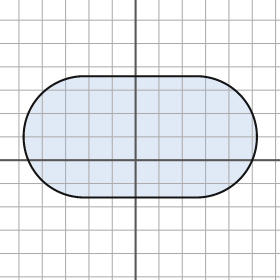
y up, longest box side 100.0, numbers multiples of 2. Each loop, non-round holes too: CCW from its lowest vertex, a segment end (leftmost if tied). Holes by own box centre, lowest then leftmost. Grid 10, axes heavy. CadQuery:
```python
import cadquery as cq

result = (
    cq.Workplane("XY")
    .moveTo(-22.0, -16.0)
    .lineTo(26.0, -16.0)
    .threePointArc((52.0, 10.0), (26.0, 36.0))
    .lineTo(-22.0, 36.0)
    .threePointArc((-48.0, 10.0), (-22.0, -16.0))
    .close()
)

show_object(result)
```